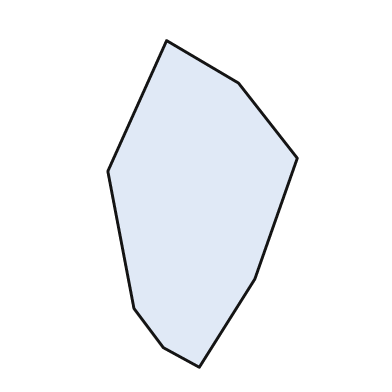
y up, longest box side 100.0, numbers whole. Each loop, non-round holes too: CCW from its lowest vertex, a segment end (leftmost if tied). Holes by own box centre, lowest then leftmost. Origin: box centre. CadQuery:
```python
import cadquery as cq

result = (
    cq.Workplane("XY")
    .moveTo(-1.0, -50.0)
    .lineTo(16.0, -23.0)
    .lineTo(29.0, 14.0)
    .lineTo(11.0, 37.0)
    .lineTo(-11.0, 50.0)
    .lineTo(-29.0, 10.0)
    .lineTo(-21.0, -32.0)
    .lineTo(-12.0, -44.0)
    .close()
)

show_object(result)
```